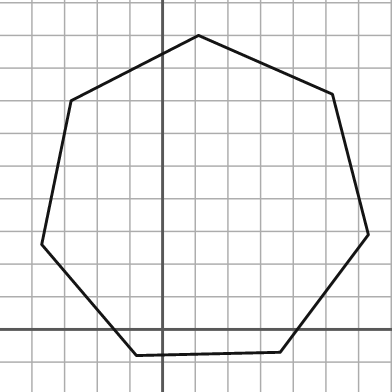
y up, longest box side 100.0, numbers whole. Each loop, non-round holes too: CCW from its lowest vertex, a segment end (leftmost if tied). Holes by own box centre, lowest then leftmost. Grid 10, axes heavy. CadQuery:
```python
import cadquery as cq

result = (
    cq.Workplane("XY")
    .moveTo(-8.0, -8.0)
    .lineTo(36.0, -7.0)
    .lineTo(63.0, 29.0)
    .lineTo(52.0, 72.0)
    .lineTo(11.0, 90.0)
    .lineTo(-28.0, 70.0)
    .lineTo(-37.0, 26.0)
    .close()
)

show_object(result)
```